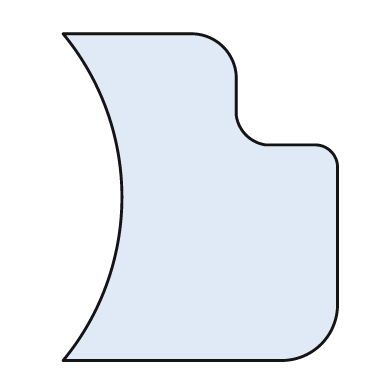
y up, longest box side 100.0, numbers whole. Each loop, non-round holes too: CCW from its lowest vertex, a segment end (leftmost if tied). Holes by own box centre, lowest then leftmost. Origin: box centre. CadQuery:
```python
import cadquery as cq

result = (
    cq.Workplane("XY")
    .moveTo(-42.0, -50.0)
    .lineTo(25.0, -50.0)
    .threePointArc((37.0, -45.0), (42.0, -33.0))
    .lineTo(42.0, 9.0)
    .threePointArc((40.0, 14.0), (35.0, 16.0))
    .lineTo(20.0, 16.0)
    .threePointArc((14.0, 19.0), (11.0, 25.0))
    .lineTo(11.0, 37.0)
    .threePointArc((7.0, 46.0), (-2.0, 50.0))
    .lineTo(-42.0, 50.0)
    .threePointArc((-24.0, 0.0), (-42.0, -50.0))
    .close()
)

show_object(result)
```